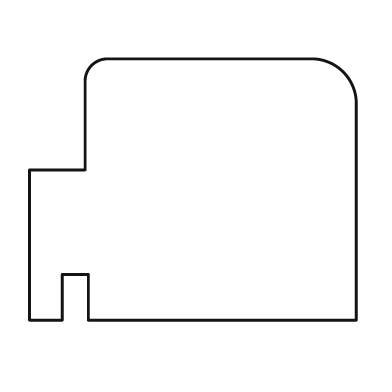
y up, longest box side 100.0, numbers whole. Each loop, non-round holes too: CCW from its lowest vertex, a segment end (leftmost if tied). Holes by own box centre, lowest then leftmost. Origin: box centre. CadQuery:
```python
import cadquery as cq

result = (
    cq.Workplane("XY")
    .moveTo(-50.0, -40.0)
    .lineTo(-40.0, -40.0)
    .lineTo(-40.0, -26.0)
    .lineTo(-32.0, -26.0)
    .lineTo(-32.0, -40.0)
    .lineTo(50.0, -40.0)
    .lineTo(50.0, 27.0)
    .threePointArc((46.0, 36.0), (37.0, 40.0))
    .lineTo(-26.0, 40.0)
    .threePointArc((-31.0, 38.0), (-33.0, 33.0))
    .lineTo(-33.0, 6.0)
    .lineTo(-50.0, 6.0)
    .close()
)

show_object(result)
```